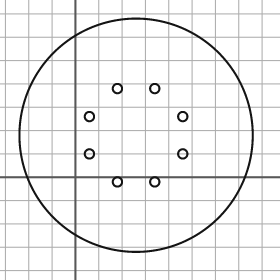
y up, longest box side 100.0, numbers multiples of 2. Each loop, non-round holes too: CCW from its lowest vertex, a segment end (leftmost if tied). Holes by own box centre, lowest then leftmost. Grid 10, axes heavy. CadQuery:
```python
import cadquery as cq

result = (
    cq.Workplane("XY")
    .moveTo(26.0, 18.0)
    .circle(50.0)
    .moveTo(18.0, -2.0)
    .circle(2.0)
    .moveTo(34.0, -2.0)
    .circle(2.0)
    .moveTo(6.0, 10.0)
    .circle(2.0)
    .moveTo(46.0, 10.0)
    .circle(2.0)
    .moveTo(6.0, 26.0)
    .circle(2.0)
    .moveTo(46.0, 26.0)
    .circle(2.0)
    .moveTo(18.0, 38.0)
    .circle(2.0)
    .moveTo(34.0, 38.0)
    .circle(2.0)
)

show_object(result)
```